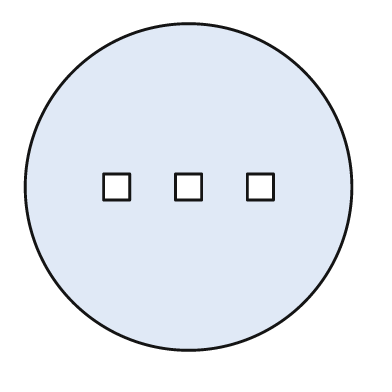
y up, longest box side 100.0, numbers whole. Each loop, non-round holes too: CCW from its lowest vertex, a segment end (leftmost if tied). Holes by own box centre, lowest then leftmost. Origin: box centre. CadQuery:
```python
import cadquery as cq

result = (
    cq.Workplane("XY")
    .moveTo(0.0, 0.0)
    .circle(50.0)
    .moveTo(-26.0, -4.0)
    .lineTo(-18.0, -4.0)
    .lineTo(-18.0, 4.0)
    .lineTo(-26.0, 4.0)
    .close()
    .moveTo(-4.0, -4.0)
    .lineTo(4.0, -4.0)
    .lineTo(4.0, 4.0)
    .lineTo(-4.0, 4.0)
    .close()
    .moveTo(18.0, -4.0)
    .lineTo(26.0, -4.0)
    .lineTo(26.0, 4.0)
    .lineTo(18.0, 4.0)
    .close()
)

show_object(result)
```